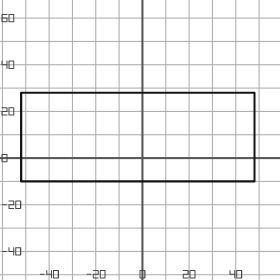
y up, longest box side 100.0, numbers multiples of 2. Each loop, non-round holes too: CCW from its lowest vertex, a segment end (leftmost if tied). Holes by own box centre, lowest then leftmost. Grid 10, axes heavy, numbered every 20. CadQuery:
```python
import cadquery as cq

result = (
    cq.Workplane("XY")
    .moveTo(-52.0, -10.0)
    .lineTo(48.0, -10.0)
    .lineTo(48.0, 28.0)
    .lineTo(-52.0, 28.0)
    .close()
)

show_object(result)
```